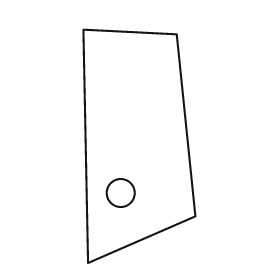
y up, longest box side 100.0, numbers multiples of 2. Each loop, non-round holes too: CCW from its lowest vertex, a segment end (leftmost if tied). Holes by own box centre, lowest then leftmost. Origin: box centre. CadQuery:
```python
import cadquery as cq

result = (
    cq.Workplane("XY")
    .moveTo(-22.0, -50.0)
    .lineTo(24.0, -30.0)
    .lineTo(16.0, 48.0)
    .lineTo(-24.0, 50.0)
    .close()
    .moveTo(-8.0, -20.0)
    .circle(6.0)
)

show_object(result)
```